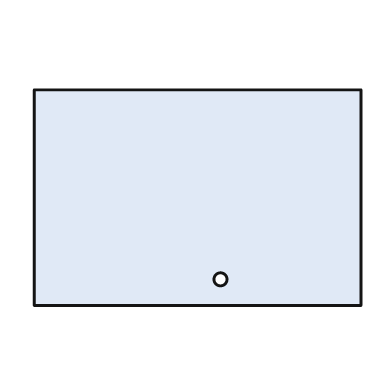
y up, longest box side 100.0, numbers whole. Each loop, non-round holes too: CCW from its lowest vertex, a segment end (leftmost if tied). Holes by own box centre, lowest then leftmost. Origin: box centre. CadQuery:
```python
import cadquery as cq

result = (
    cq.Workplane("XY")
    .moveTo(-50.0, -33.0)
    .lineTo(50.0, -33.0)
    .lineTo(50.0, 33.0)
    .lineTo(-50.0, 33.0)
    .close()
    .moveTo(7.0, -25.0)
    .circle(2.0)
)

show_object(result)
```